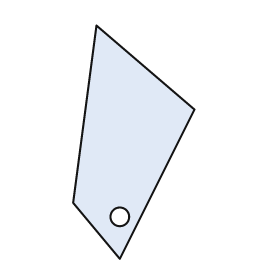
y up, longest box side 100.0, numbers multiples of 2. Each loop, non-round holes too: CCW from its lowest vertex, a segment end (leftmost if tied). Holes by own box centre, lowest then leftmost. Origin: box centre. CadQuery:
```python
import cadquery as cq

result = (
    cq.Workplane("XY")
    .moveTo(-6.0, -50.0)
    .lineTo(26.0, 14.0)
    .lineTo(-16.0, 50.0)
    .lineTo(-26.0, -26.0)
    .close()
    .moveTo(-6.0, -32.0)
    .circle(4.0)
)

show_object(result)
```